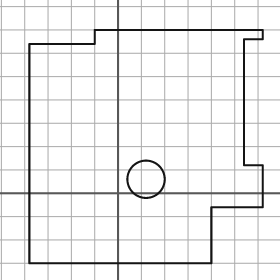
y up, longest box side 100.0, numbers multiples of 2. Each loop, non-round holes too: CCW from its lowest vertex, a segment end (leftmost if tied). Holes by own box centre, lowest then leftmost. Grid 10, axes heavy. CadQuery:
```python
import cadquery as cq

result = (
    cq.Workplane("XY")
    .moveTo(-38.0, -30.0)
    .lineTo(40.0, -30.0)
    .lineTo(40.0, -6.0)
    .lineTo(62.0, -6.0)
    .lineTo(62.0, 12.0)
    .lineTo(54.0, 12.0)
    .lineTo(54.0, 66.0)
    .lineTo(62.0, 66.0)
    .lineTo(62.0, 70.0)
    .lineTo(-10.0, 70.0)
    .lineTo(-10.0, 64.0)
    .lineTo(-38.0, 64.0)
    .close()
    .moveTo(12.0, 6.0)
    .circle(8.0)
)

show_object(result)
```